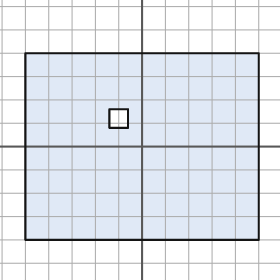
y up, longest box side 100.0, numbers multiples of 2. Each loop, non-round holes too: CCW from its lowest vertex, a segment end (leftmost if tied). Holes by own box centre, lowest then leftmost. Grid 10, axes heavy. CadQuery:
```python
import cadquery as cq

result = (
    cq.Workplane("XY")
    .moveTo(-50.0, -40.0)
    .lineTo(50.0, -40.0)
    .lineTo(50.0, 40.0)
    .lineTo(-50.0, 40.0)
    .close()
    .moveTo(-14.0, 8.0)
    .lineTo(-6.0, 8.0)
    .lineTo(-6.0, 16.0)
    .lineTo(-14.0, 16.0)
    .close()
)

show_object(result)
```